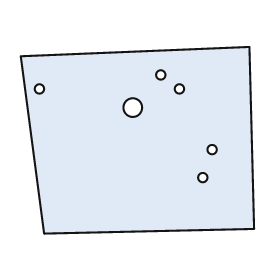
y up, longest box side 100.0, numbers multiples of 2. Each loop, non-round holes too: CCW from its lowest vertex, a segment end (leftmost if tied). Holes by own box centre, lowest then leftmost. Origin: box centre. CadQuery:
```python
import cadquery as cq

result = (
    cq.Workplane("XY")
    .moveTo(-40.0, -40.0)
    .lineTo(50.0, -38.0)
    .lineTo(48.0, 40.0)
    .lineTo(-50.0, 36.0)
    .close()
    .moveTo(28.0, -16.0)
    .circle(2.0)
    .moveTo(32.0, -4.0)
    .circle(2.0)
    .moveTo(-2.0, 14.0)
    .circle(4.0)
    .moveTo(-42.0, 22.0)
    .circle(2.0)
    .moveTo(18.0, 22.0)
    .circle(2.0)
    .moveTo(10.0, 28.0)
    .circle(2.0)
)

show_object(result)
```